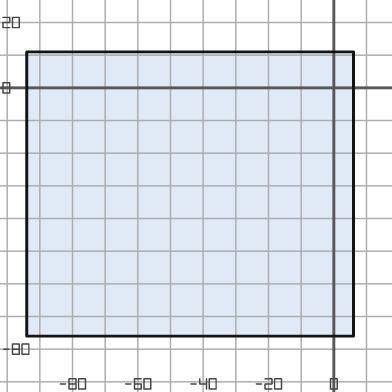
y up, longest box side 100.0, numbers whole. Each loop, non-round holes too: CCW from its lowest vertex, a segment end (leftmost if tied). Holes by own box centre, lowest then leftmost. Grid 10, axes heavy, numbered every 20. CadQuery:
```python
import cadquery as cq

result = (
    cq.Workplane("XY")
    .moveTo(-94.0, -76.0)
    .lineTo(6.0, -76.0)
    .lineTo(6.0, 11.0)
    .lineTo(-94.0, 11.0)
    .close()
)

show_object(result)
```